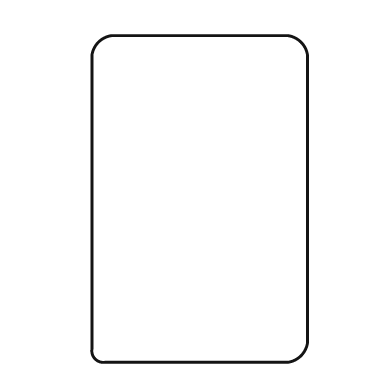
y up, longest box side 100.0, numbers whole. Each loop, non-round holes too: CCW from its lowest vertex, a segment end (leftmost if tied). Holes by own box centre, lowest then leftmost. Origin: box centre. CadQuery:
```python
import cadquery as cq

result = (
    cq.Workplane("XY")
    .moveTo(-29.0, -50.0)
    .lineTo(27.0, -50.0)
    .threePointArc((31.0, -48.0), (33.0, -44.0))
    .lineTo(33.0, 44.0)
    .threePointArc((31.0, 48.0), (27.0, 50.0))
    .lineTo(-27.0, 50.0)
    .threePointArc((-31.0, 48.0), (-33.0, 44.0))
    .lineTo(-33.0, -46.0)
    .threePointArc((-32.0, -49.0), (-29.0, -50.0))
    .close()
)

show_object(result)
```